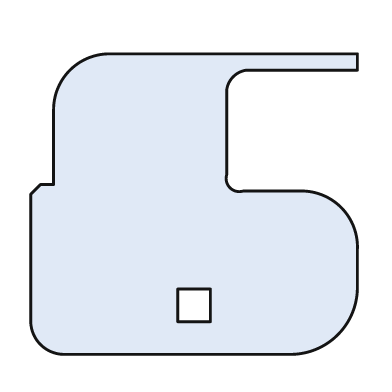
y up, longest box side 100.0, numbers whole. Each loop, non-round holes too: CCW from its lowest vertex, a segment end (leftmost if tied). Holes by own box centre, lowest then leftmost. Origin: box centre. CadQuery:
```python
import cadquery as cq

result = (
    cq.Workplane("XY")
    .moveTo(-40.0, -46.0)
    .lineTo(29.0, -46.0)
    .threePointArc((44.0, -40.0), (50.0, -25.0))
    .lineTo(50.0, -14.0)
    .threePointArc((45.0, -1.0), (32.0, 4.0))
    .lineTo(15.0, 4.0)
    .threePointArc((11.0, 5.0), (10.0, 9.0))
    .lineTo(10.0, 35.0)
    .threePointArc((12.0, 39.0), (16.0, 41.0))
    .lineTo(50.0, 41.0)
    .lineTo(50.0, 46.0)
    .lineTo(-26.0, 46.0)
    .threePointArc((-38.0, 41.0), (-43.0, 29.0))
    .lineTo(-43.0, 6.0)
    .lineTo(-47.0, 6.0)
    .lineTo(-50.0, 3.0)
    .lineTo(-50.0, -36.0)
    .threePointArc((-47.0, -43.0), (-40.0, -46.0))
    .close()
    .moveTo(-5.0, -36.0)
    .lineTo(5.0, -36.0)
    .lineTo(5.0, -26.0)
    .lineTo(-5.0, -26.0)
    .close()
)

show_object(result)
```